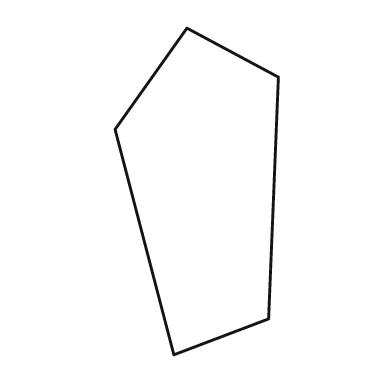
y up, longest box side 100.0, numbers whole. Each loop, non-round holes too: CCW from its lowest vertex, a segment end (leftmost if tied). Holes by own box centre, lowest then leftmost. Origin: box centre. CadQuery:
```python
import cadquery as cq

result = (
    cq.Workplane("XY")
    .moveTo(-7.0, -50.0)
    .lineTo(22.0, -39.0)
    .lineTo(25.0, 35.0)
    .lineTo(-3.0, 50.0)
    .lineTo(-25.0, 19.0)
    .close()
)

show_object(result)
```